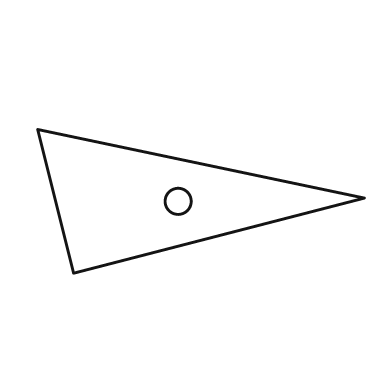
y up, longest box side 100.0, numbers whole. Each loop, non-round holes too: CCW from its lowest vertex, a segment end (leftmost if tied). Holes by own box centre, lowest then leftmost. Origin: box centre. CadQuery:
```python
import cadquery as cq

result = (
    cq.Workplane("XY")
    .moveTo(-39.0, -22.0)
    .lineTo(50.0, 1.0)
    .lineTo(-50.0, 22.0)
    .close()
    .moveTo(-7.0, 0.0)
    .circle(4.0)
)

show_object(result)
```